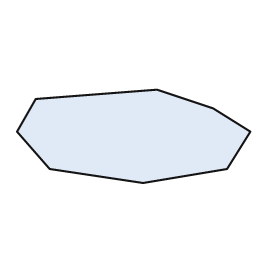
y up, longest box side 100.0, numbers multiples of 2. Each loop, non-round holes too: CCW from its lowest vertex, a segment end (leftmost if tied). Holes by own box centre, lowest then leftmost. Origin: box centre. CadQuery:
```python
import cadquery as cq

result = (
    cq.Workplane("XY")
    .moveTo(4.0, -20.0)
    .lineTo(40.0, -14.0)
    .lineTo(50.0, 2.0)
    .lineTo(34.0, 12.0)
    .lineTo(10.0, 20.0)
    .lineTo(-42.0, 16.0)
    .lineTo(-50.0, 2.0)
    .lineTo(-36.0, -14.0)
    .close()
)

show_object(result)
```